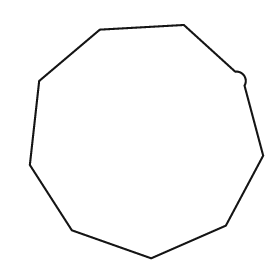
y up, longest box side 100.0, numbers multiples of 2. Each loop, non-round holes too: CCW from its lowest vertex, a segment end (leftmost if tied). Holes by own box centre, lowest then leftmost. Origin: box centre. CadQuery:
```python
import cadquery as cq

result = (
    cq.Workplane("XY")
    .moveTo(2.0, -50.0)
    .lineTo(34.0, -36.0)
    .lineTo(50.0, -6.0)
    .lineTo(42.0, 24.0)
    .threePointArc((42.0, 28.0), (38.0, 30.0))
    .lineTo(16.0, 50.0)
    .lineTo(-20.0, 48.0)
    .lineTo(-46.0, 26.0)
    .lineTo(-50.0, -10.0)
    .lineTo(-32.0, -38.0)
    .close()
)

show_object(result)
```